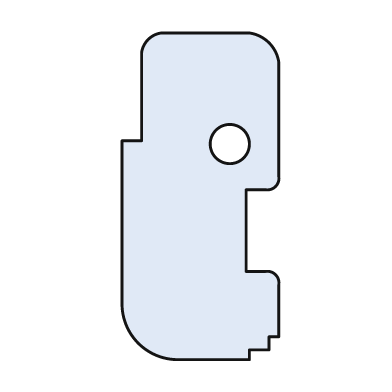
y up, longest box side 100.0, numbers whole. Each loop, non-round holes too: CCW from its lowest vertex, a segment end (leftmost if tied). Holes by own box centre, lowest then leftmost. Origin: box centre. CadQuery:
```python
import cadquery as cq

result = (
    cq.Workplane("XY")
    .moveTo(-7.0, -50.0)
    .lineTo(15.0, -50.0)
    .lineTo(15.0, -47.0)
    .lineTo(21.0, -47.0)
    .lineTo(21.0, -43.0)
    .lineTo(24.0, -43.0)
    .lineTo(24.0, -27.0)
    .threePointArc((23.0, -24.0), (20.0, -23.0))
    .lineTo(14.0, -23.0)
    .lineTo(14.0, 2.0)
    .lineTo(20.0, 2.0)
    .threePointArc((23.0, 3.0), (24.0, 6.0))
    .lineTo(24.0, 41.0)
    .threePointArc((21.0, 47.0), (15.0, 50.0))
    .lineTo(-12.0, 50.0)
    .threePointArc((-16.0, 48.0), (-18.0, 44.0))
    .lineTo(-18.0, 17.0)
    .lineTo(-24.0, 17.0)
    .lineTo(-24.0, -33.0)
    .threePointArc((-19.0, -45.0), (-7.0, -50.0))
    .close()
    .moveTo(9.0, 16.0)
    .circle(6.0)
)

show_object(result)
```